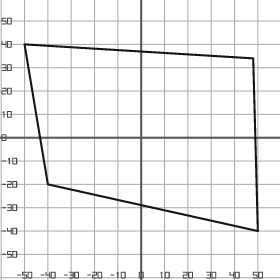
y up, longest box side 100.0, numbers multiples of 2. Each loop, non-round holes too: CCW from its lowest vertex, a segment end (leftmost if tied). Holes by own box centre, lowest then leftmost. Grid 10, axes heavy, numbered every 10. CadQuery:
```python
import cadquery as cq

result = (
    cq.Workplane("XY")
    .moveTo(50.0, -40.0)
    .lineTo(48.0, 34.0)
    .lineTo(-50.0, 40.0)
    .lineTo(-40.0, -20.0)
    .close()
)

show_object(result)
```